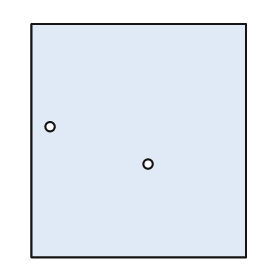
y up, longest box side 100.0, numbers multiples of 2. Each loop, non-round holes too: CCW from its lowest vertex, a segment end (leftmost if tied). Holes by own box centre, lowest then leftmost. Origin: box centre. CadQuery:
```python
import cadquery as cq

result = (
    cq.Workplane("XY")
    .moveTo(-46.0, -50.0)
    .lineTo(46.0, -50.0)
    .lineTo(46.0, 50.0)
    .lineTo(-46.0, 50.0)
    .close()
    .moveTo(4.0, -10.0)
    .circle(2.0)
    .moveTo(-38.0, 6.0)
    .circle(2.0)
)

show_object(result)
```